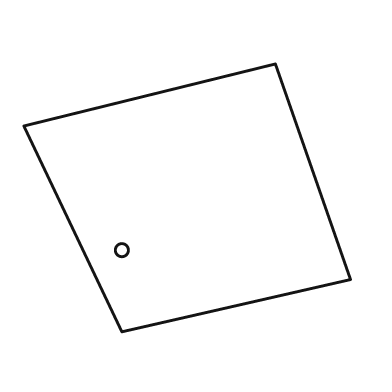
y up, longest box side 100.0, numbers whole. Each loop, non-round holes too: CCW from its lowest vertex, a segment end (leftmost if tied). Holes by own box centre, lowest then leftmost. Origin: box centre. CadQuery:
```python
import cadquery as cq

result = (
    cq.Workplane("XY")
    .moveTo(-20.0, -41.0)
    .lineTo(50.0, -25.0)
    .lineTo(27.0, 41.0)
    .lineTo(-50.0, 22.0)
    .close()
    .moveTo(-20.0, -16.0)
    .circle(2.0)
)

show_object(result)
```